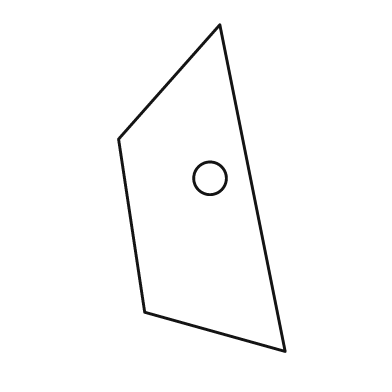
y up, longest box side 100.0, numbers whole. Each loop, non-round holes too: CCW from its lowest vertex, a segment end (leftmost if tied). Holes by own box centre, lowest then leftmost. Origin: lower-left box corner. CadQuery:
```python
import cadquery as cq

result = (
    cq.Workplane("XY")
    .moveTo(51.0, 0.0)
    .lineTo(31.0, 100.0)
    .lineTo(0.0, 65.0)
    .lineTo(8.0, 12.0)
    .close()
    .moveTo(28.0, 53.0)
    .circle(5.0)
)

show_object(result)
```